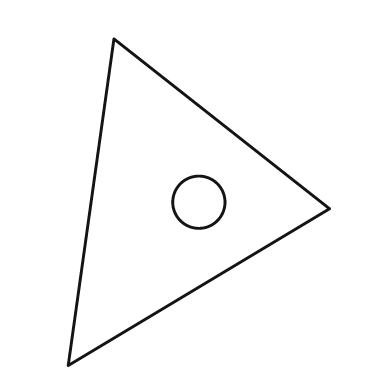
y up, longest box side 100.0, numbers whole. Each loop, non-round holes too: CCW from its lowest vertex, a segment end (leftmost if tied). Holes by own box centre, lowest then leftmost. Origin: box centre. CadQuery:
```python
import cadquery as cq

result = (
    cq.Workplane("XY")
    .moveTo(-40.0, -50.0)
    .lineTo(40.0, -2.0)
    .lineTo(-26.0, 50.0)
    .close()
    .moveTo(0.0, 0.0)
    .circle(8.0)
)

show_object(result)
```